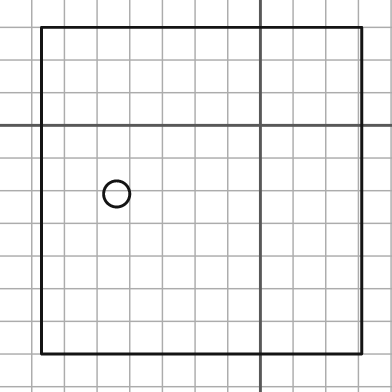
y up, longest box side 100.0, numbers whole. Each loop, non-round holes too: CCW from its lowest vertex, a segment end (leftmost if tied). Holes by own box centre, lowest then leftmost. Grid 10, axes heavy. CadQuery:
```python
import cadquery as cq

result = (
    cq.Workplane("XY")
    .moveTo(-67.0, -70.0)
    .lineTo(31.0, -70.0)
    .lineTo(31.0, 30.0)
    .lineTo(-67.0, 30.0)
    .close()
    .moveTo(-44.0, -21.0)
    .circle(4.0)
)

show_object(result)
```